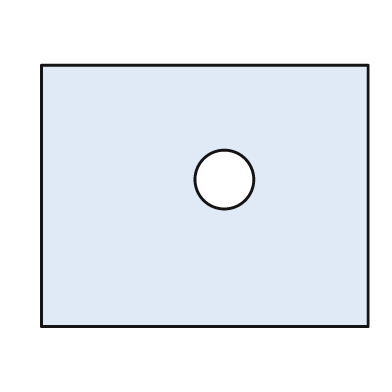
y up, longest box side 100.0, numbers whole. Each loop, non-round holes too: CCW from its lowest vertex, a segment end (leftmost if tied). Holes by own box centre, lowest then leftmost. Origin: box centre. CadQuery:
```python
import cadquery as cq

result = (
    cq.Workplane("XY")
    .moveTo(-50.0, -40.0)
    .lineTo(50.0, -40.0)
    .lineTo(50.0, 40.0)
    .lineTo(-50.0, 40.0)
    .close()
    .moveTo(6.0, 5.0)
    .circle(9.0)
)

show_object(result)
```